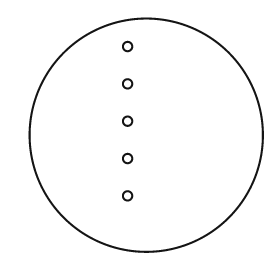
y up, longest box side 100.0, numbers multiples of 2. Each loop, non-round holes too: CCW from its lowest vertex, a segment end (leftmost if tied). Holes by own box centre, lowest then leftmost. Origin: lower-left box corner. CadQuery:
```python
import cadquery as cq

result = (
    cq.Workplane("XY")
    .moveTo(50.0, 50.0)
    .circle(50.0)
    .moveTo(42.0, 24.0)
    .circle(2.0)
    .moveTo(42.0, 40.0)
    .circle(2.0)
    .moveTo(42.0, 56.0)
    .circle(2.0)
    .moveTo(42.0, 72.0)
    .circle(2.0)
    .moveTo(42.0, 88.0)
    .circle(2.0)
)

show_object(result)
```